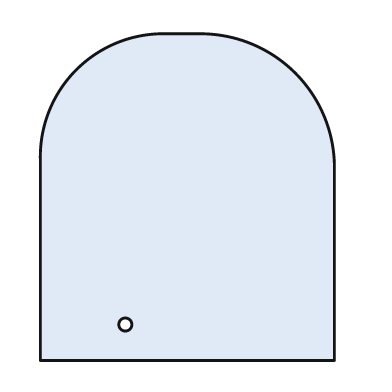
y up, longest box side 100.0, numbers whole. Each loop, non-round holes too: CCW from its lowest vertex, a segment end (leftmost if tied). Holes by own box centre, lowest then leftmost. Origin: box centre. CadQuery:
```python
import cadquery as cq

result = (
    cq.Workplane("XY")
    .moveTo(-45.0, -50.0)
    .lineTo(45.0, -50.0)
    .lineTo(45.0, 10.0)
    .threePointArc((33.0, 38.0), (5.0, 50.0))
    .lineTo(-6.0, 50.0)
    .threePointArc((-34.0, 39.0), (-45.0, 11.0))
    .close()
    .moveTo(-19.0, -39.0)
    .circle(2.0)
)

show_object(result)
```